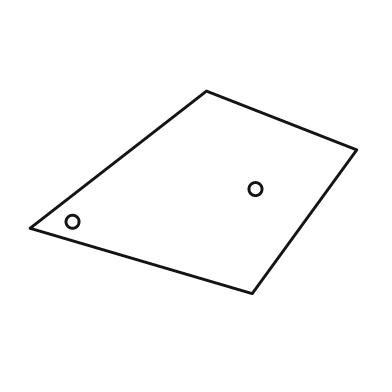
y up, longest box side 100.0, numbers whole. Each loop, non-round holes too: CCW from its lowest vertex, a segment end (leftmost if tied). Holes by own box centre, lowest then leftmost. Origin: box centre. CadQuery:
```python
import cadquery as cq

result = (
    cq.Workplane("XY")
    .moveTo(18.0, -31.0)
    .lineTo(50.0, 13.0)
    .lineTo(4.0, 31.0)
    .lineTo(-50.0, -11.0)
    .close()
    .moveTo(-37.0, -9.0)
    .circle(2.0)
    .moveTo(19.0, 1.0)
    .circle(2.0)
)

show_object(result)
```